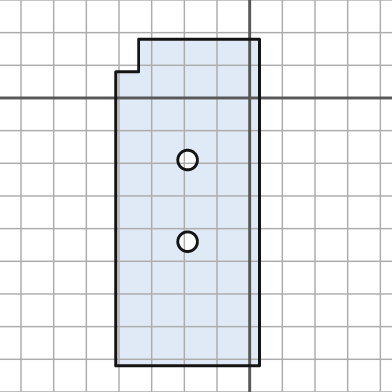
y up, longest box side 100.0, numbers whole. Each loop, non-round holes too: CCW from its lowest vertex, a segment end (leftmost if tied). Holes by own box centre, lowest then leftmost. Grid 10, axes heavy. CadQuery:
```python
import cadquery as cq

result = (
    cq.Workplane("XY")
    .moveTo(-41.0, -82.0)
    .lineTo(3.0, -82.0)
    .lineTo(3.0, 18.0)
    .lineTo(-34.0, 18.0)
    .lineTo(-34.0, 8.0)
    .lineTo(-41.0, 8.0)
    .close()
    .moveTo(-19.0, -44.0)
    .circle(3.0)
    .moveTo(-19.0, -19.0)
    .circle(3.0)
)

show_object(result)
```